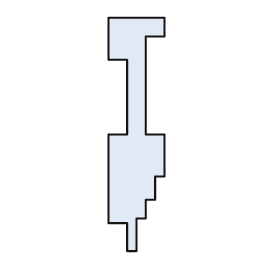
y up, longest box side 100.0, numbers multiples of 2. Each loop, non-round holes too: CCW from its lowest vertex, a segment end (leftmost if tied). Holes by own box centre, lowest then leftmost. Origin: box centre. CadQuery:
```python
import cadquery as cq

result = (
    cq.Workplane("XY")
    .moveTo(-4.0, -50.0)
    .lineTo(0.0, -50.0)
    .lineTo(0.0, -36.0)
    .lineTo(4.0, -36.0)
    .lineTo(4.0, -28.0)
    .lineTo(8.0, -28.0)
    .lineTo(8.0, -18.0)
    .lineTo(12.0, -18.0)
    .lineTo(12.0, 0.0)
    .lineTo(4.0, 0.0)
    .lineTo(4.0, 42.0)
    .lineTo(12.0, 42.0)
    .lineTo(12.0, 50.0)
    .lineTo(-12.0, 50.0)
    .lineTo(-12.0, 32.0)
    .lineTo(-4.0, 32.0)
    .lineTo(-4.0, 0.0)
    .lineTo(-12.0, 0.0)
    .lineTo(-12.0, -38.0)
    .lineTo(-4.0, -38.0)
    .close()
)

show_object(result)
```